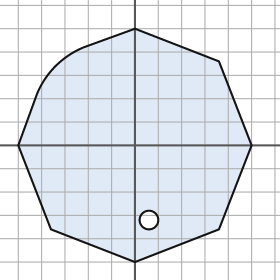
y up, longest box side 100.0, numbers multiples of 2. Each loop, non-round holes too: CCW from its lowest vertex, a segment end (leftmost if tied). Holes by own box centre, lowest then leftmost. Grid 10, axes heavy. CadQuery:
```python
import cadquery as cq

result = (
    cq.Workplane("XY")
    .moveTo(0.0, -50.0)
    .lineTo(36.0, -36.0)
    .lineTo(50.0, 0.0)
    .lineTo(36.0, 36.0)
    .lineTo(0.0, 50.0)
    .lineTo(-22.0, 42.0)
    .threePointArc((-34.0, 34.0), (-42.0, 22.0))
    .lineTo(-50.0, 0.0)
    .lineTo(-36.0, -36.0)
    .close()
    .moveTo(6.0, -32.0)
    .circle(4.0)
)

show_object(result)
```